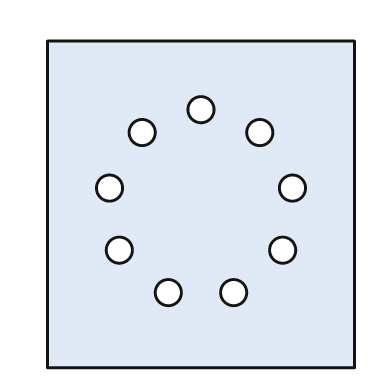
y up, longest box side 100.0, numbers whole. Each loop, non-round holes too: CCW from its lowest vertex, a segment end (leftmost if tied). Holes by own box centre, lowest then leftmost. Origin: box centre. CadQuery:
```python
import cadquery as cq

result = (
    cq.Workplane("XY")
    .moveTo(-47.0, -50.0)
    .lineTo(47.0, -50.0)
    .lineTo(47.0, 50.0)
    .lineTo(-47.0, 50.0)
    .close()
    .moveTo(-10.0, -27.0)
    .circle(4.0)
    .moveTo(10.0, -27.0)
    .circle(4.0)
    .moveTo(-25.0, -14.0)
    .circle(4.0)
    .moveTo(25.0, -14.0)
    .circle(4.0)
    .moveTo(-28.0, 5.0)
    .circle(4.0)
    .moveTo(28.0, 5.0)
    .circle(4.0)
    .moveTo(-18.0, 22.0)
    .circle(4.0)
    .moveTo(18.0, 22.0)
    .circle(4.0)
    .moveTo(0.0, 29.0)
    .circle(4.0)
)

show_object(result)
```